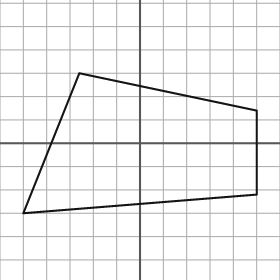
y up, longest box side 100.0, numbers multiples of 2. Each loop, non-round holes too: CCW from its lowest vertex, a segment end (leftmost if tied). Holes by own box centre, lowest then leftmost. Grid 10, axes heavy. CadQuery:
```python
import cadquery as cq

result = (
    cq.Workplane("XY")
    .moveTo(-50.0, -30.0)
    .lineTo(50.0, -22.0)
    .lineTo(50.0, 14.0)
    .lineTo(-26.0, 30.0)
    .close()
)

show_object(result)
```